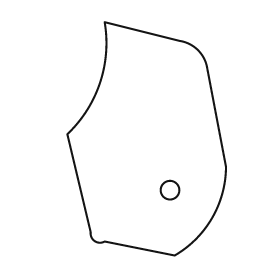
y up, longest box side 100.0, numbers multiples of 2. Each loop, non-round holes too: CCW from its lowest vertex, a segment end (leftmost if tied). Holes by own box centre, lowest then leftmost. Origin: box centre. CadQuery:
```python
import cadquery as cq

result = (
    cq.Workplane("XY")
    .moveTo(12.0, -50.0)
    .threePointArc((28.0, -34.0), (34.0, -12.0))
    .lineTo(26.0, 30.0)
    .threePointArc((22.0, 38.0), (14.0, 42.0))
    .lineTo(-18.0, 50.0)
    .threePointArc((-20.0, 24.0), (-34.0, 2.0))
    .lineTo(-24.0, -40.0)
    .threePointArc((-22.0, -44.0), (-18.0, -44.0))
    .close()
    .moveTo(10.0, -22.0)
    .circle(4.0)
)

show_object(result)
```